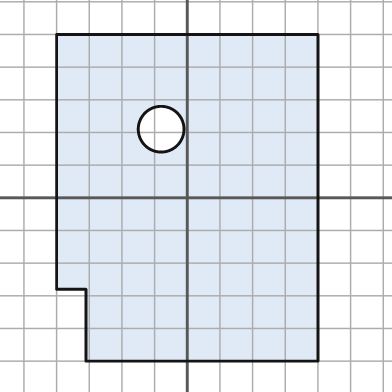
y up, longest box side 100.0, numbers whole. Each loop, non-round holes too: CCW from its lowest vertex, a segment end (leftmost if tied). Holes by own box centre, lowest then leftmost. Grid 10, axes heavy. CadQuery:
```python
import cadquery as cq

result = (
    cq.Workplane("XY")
    .moveTo(-31.0, -50.0)
    .lineTo(40.0, -50.0)
    .lineTo(40.0, 50.0)
    .lineTo(-40.0, 50.0)
    .lineTo(-40.0, -28.0)
    .lineTo(-31.0, -28.0)
    .close()
    .moveTo(-8.0, 21.0)
    .circle(7.0)
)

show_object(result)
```